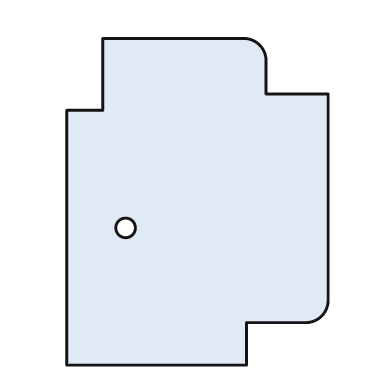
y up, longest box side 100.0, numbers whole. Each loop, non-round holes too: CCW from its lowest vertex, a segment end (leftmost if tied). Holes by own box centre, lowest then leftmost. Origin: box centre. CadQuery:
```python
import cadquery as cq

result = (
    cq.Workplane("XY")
    .moveTo(-40.0, -50.0)
    .lineTo(15.0, -50.0)
    .lineTo(15.0, -37.0)
    .lineTo(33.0, -37.0)
    .threePointArc((38.0, -35.0), (40.0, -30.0))
    .lineTo(40.0, 33.0)
    .lineTo(21.0, 33.0)
    .lineTo(21.0, 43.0)
    .threePointArc((19.0, 48.0), (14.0, 50.0))
    .lineTo(-29.0, 50.0)
    .lineTo(-29.0, 28.0)
    .lineTo(-40.0, 28.0)
    .close()
    .moveTo(-22.0, -8.0)
    .circle(3.0)
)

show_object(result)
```